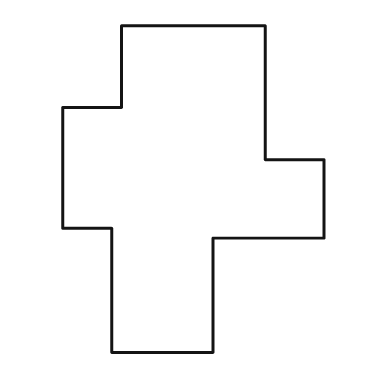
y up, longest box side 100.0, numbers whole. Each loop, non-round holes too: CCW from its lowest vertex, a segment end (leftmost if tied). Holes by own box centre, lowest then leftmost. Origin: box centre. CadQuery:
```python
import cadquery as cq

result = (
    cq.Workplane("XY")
    .moveTo(-25.0, -50.0)
    .lineTo(6.0, -50.0)
    .lineTo(6.0, -15.0)
    .lineTo(40.0, -15.0)
    .lineTo(40.0, 9.0)
    .lineTo(22.0, 9.0)
    .lineTo(22.0, 50.0)
    .lineTo(-22.0, 50.0)
    .lineTo(-22.0, 25.0)
    .lineTo(-40.0, 25.0)
    .lineTo(-40.0, -12.0)
    .lineTo(-25.0, -12.0)
    .close()
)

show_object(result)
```